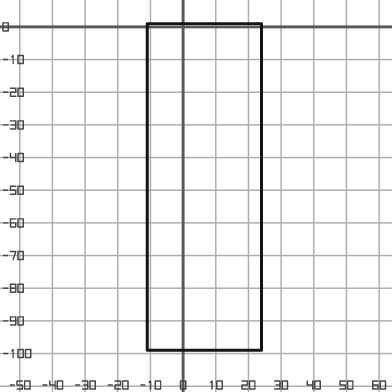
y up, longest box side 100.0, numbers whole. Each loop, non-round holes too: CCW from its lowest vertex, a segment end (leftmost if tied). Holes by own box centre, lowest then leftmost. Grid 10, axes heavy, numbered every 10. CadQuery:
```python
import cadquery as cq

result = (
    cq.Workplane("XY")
    .moveTo(-11.0, -99.0)
    .lineTo(24.0, -99.0)
    .lineTo(24.0, 1.0)
    .lineTo(-11.0, 1.0)
    .close()
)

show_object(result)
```